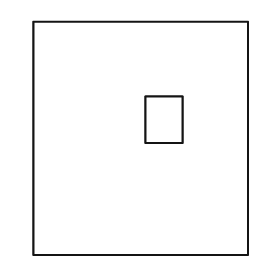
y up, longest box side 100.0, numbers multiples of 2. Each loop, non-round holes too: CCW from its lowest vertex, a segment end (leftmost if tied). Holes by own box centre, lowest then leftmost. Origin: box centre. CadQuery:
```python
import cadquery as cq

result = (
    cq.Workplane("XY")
    .moveTo(-46.0, -50.0)
    .lineTo(46.0, -50.0)
    .lineTo(46.0, 50.0)
    .lineTo(-46.0, 50.0)
    .close()
    .moveTo(2.0, -2.0)
    .lineTo(18.0, -2.0)
    .lineTo(18.0, 18.0)
    .lineTo(2.0, 18.0)
    .close()
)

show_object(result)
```